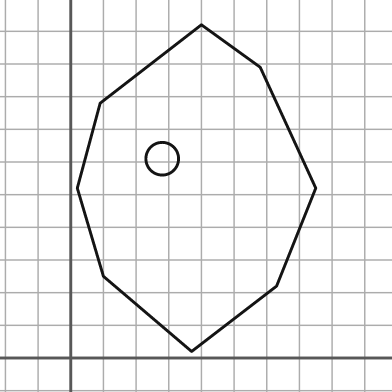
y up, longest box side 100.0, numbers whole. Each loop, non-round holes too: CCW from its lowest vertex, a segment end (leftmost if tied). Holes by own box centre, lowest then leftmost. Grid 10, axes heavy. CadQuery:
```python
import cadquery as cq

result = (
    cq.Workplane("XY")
    .moveTo(37.0, 2.0)
    .lineTo(63.0, 22.0)
    .lineTo(75.0, 52.0)
    .lineTo(58.0, 89.0)
    .lineTo(40.0, 102.0)
    .lineTo(9.0, 78.0)
    .lineTo(2.0, 52.0)
    .lineTo(10.0, 25.0)
    .close()
    .moveTo(28.0, 61.0)
    .circle(5.0)
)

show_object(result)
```